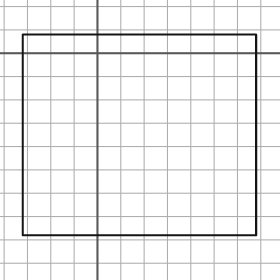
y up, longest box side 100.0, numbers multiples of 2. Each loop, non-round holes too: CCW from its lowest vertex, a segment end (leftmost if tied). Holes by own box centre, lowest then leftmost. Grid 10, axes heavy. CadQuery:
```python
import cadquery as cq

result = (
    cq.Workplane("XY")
    .moveTo(-32.0, -78.0)
    .lineTo(68.0, -78.0)
    .lineTo(68.0, 8.0)
    .lineTo(-32.0, 8.0)
    .close()
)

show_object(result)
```